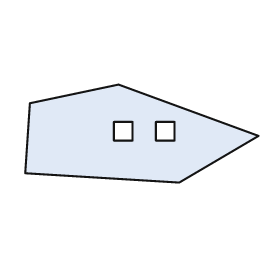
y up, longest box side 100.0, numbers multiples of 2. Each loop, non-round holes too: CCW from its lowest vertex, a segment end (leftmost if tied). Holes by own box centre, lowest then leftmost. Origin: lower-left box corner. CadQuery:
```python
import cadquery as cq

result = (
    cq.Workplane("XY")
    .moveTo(66.0, 0.0)
    .lineTo(100.0, 20.0)
    .lineTo(40.0, 42.0)
    .lineTo(2.0, 34.0)
    .lineTo(0.0, 4.0)
    .close()
    .moveTo(38.0, 18.0)
    .lineTo(46.0, 18.0)
    .lineTo(46.0, 26.0)
    .lineTo(38.0, 26.0)
    .close()
    .moveTo(56.0, 18.0)
    .lineTo(64.0, 18.0)
    .lineTo(64.0, 26.0)
    .lineTo(56.0, 26.0)
    .close()
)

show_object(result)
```